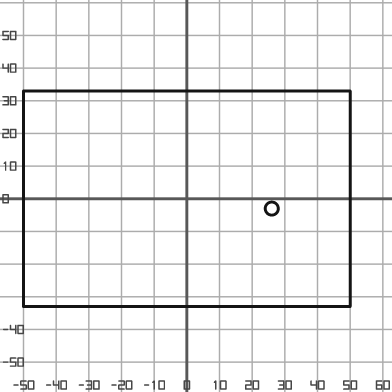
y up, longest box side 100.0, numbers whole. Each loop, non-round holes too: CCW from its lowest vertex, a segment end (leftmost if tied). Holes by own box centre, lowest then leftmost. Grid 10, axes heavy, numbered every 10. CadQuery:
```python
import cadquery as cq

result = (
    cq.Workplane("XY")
    .moveTo(-50.0, -33.0)
    .lineTo(50.0, -33.0)
    .lineTo(50.0, 33.0)
    .lineTo(-50.0, 33.0)
    .close()
    .moveTo(26.0, -3.0)
    .circle(2.0)
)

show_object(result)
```